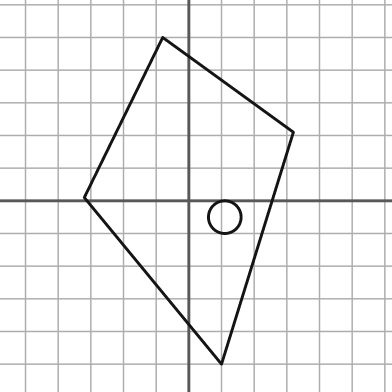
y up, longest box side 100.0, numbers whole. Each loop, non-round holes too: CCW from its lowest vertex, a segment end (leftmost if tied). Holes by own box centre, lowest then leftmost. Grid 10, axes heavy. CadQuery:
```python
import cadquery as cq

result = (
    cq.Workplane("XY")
    .moveTo(10.0, -50.0)
    .lineTo(32.0, 21.0)
    .lineTo(-8.0, 50.0)
    .lineTo(-32.0, 1.0)
    .close()
    .moveTo(11.0, -5.0)
    .circle(5.0)
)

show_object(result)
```